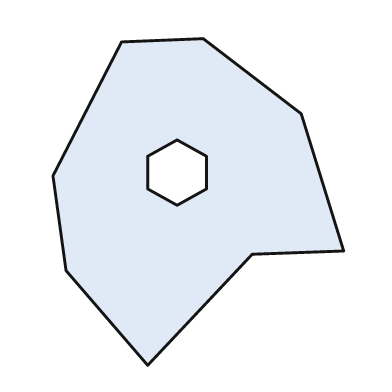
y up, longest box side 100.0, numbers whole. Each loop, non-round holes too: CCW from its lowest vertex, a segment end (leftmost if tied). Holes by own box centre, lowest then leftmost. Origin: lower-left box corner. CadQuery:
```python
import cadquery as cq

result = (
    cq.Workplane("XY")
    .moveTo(29.0, 0.0)
    .lineTo(61.0, 34.0)
    .lineTo(89.0, 35.0)
    .lineTo(76.0, 77.0)
    .lineTo(46.0, 100.0)
    .lineTo(21.0, 99.0)
    .lineTo(0.0, 58.0)
    .lineTo(4.0, 29.0)
    .close()
    .moveTo(38.0, 49.0)
    .lineTo(47.0, 54.0)
    .lineTo(47.0, 64.0)
    .lineTo(38.0, 69.0)
    .lineTo(29.0, 64.0)
    .lineTo(29.0, 54.0)
    .close()
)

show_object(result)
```